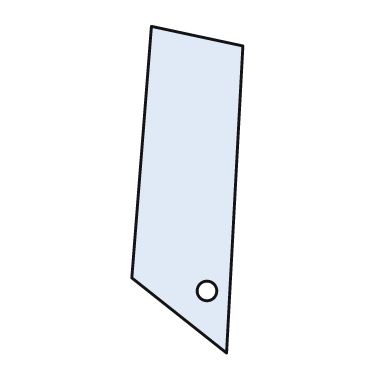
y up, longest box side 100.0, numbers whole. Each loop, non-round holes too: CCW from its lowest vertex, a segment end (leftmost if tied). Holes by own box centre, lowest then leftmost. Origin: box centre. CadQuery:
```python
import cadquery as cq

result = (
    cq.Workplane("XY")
    .moveTo(12.0, -50.0)
    .lineTo(17.0, 44.0)
    .lineTo(-11.0, 50.0)
    .lineTo(-17.0, -27.0)
    .close()
    .moveTo(6.0, -31.0)
    .circle(3.0)
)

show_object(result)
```